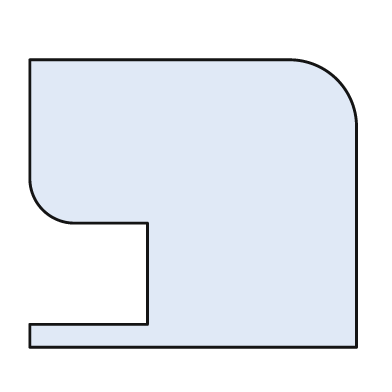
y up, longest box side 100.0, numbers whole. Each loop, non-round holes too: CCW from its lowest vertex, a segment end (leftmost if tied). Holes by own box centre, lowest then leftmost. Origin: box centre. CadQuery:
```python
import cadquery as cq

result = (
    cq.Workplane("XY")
    .moveTo(-50.0, -44.0)
    .lineTo(50.0, -44.0)
    .lineTo(50.0, 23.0)
    .threePointArc((44.0, 38.0), (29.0, 44.0))
    .lineTo(-50.0, 44.0)
    .lineTo(-50.0, 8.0)
    .threePointArc((-46.0, -2.0), (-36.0, -6.0))
    .lineTo(-14.0, -6.0)
    .lineTo(-14.0, -37.0)
    .lineTo(-50.0, -37.0)
    .close()
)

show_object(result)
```